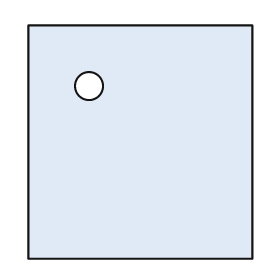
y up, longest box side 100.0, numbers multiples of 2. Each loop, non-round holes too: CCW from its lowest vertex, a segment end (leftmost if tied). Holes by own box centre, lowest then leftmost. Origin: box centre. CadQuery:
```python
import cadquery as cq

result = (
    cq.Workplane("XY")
    .moveTo(-48.0, -50.0)
    .lineTo(48.0, -50.0)
    .lineTo(48.0, 50.0)
    .lineTo(-48.0, 50.0)
    .close()
    .moveTo(-22.0, 24.0)
    .circle(6.0)
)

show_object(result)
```